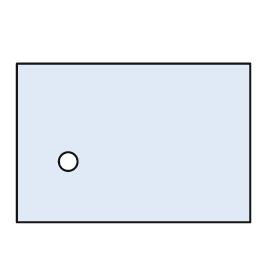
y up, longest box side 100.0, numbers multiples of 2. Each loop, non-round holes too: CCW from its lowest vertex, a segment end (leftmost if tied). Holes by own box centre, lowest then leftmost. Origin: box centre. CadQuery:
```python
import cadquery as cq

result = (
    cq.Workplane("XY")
    .moveTo(-50.0, -34.0)
    .lineTo(50.0, -34.0)
    .lineTo(50.0, 34.0)
    .lineTo(-50.0, 34.0)
    .close()
    .moveTo(-28.0, -8.0)
    .circle(4.0)
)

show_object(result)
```